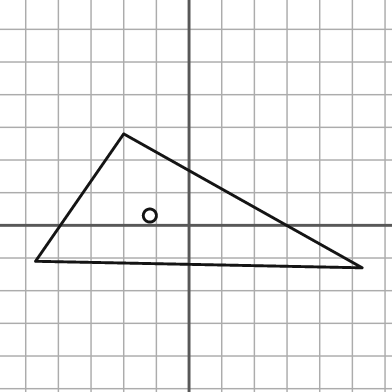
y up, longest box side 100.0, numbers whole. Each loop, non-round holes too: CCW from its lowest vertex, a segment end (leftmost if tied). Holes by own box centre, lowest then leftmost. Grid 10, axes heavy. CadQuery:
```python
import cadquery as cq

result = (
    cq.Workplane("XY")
    .moveTo(53.0, -13.0)
    .lineTo(-20.0, 28.0)
    .lineTo(-47.0, -11.0)
    .close()
    .moveTo(-12.0, 3.0)
    .circle(2.0)
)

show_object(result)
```